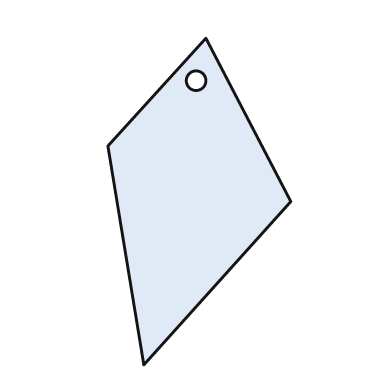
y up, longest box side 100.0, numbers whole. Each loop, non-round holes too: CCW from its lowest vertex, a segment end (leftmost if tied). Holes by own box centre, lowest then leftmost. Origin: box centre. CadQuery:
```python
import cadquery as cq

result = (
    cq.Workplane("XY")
    .moveTo(-17.0, -50.0)
    .lineTo(28.0, 0.0)
    .lineTo(2.0, 50.0)
    .lineTo(-28.0, 17.0)
    .close()
    .moveTo(-1.0, 37.0)
    .circle(3.0)
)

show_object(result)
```